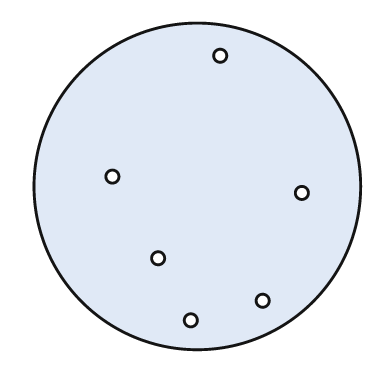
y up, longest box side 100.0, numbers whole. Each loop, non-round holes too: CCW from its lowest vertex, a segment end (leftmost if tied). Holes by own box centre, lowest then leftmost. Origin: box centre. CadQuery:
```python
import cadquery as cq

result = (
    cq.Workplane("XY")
    .moveTo(0.0, 0.0)
    .circle(50.0)
    .moveTo(-2.0, -41.0)
    .circle(2.0)
    .moveTo(20.0, -35.0)
    .circle(2.0)
    .moveTo(-12.0, -22.0)
    .circle(2.0)
    .moveTo(32.0, -2.0)
    .circle(2.0)
    .moveTo(-26.0, 3.0)
    .circle(2.0)
    .moveTo(7.0, 40.0)
    .circle(2.0)
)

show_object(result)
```